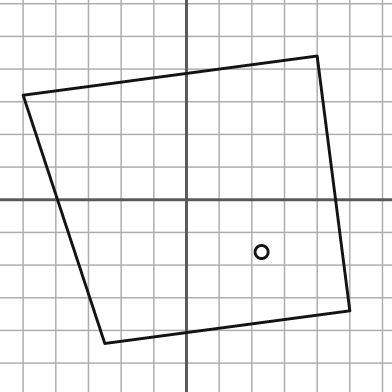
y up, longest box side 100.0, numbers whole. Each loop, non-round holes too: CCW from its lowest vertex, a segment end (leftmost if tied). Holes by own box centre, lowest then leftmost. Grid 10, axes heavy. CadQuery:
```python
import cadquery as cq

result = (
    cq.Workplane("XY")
    .moveTo(-25.0, -44.0)
    .lineTo(50.0, -34.0)
    .lineTo(40.0, 44.0)
    .lineTo(-50.0, 32.0)
    .close()
    .moveTo(23.0, -16.0)
    .circle(2.0)
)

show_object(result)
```